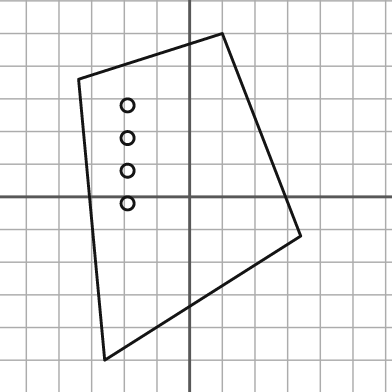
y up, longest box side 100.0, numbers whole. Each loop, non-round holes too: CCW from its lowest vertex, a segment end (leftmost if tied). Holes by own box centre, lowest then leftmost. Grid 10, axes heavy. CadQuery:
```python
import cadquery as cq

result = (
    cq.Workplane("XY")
    .moveTo(-26.0, -50.0)
    .lineTo(34.0, -12.0)
    .lineTo(10.0, 50.0)
    .lineTo(-34.0, 36.0)
    .close()
    .moveTo(-19.0, -2.0)
    .circle(2.0)
    .moveTo(-19.0, 8.0)
    .circle(2.0)
    .moveTo(-19.0, 18.0)
    .circle(2.0)
    .moveTo(-19.0, 28.0)
    .circle(2.0)
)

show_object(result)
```